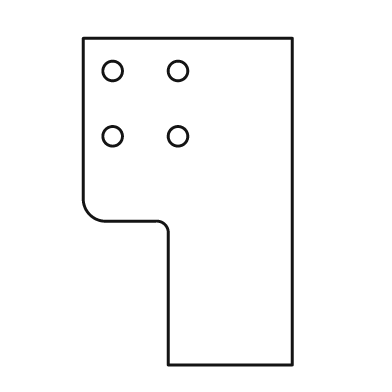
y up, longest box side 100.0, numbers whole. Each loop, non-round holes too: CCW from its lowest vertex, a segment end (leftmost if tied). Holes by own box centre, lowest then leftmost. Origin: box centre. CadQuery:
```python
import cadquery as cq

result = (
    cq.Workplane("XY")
    .moveTo(-6.0, -50.0)
    .lineTo(32.0, -50.0)
    .lineTo(32.0, 50.0)
    .lineTo(-32.0, 50.0)
    .lineTo(-32.0, 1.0)
    .threePointArc((-30.0, -4.0), (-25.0, -6.0))
    .lineTo(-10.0, -6.0)
    .threePointArc((-7.0, -7.0), (-6.0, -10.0))
    .close()
    .moveTo(-23.0, 20.0)
    .circle(3.0)
    .moveTo(-3.0, 20.0)
    .circle(3.0)
    .moveTo(-23.0, 40.0)
    .circle(3.0)
    .moveTo(-3.0, 40.0)
    .circle(3.0)
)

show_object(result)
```